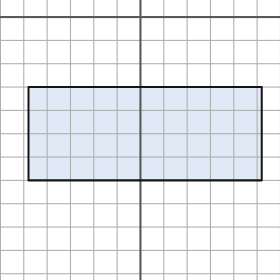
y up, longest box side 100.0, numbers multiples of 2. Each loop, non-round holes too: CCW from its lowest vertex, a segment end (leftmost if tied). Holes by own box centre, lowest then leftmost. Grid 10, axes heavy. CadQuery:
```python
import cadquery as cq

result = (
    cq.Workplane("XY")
    .moveTo(-48.0, -70.0)
    .lineTo(52.0, -70.0)
    .lineTo(52.0, -30.0)
    .lineTo(-48.0, -30.0)
    .close()
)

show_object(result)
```